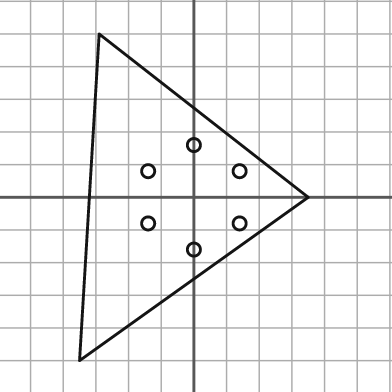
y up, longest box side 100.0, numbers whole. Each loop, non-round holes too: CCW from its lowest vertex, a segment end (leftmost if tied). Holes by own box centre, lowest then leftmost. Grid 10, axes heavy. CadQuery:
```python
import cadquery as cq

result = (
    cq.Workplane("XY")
    .moveTo(-35.0, -50.0)
    .lineTo(35.0, 0.0)
    .lineTo(-29.0, 50.0)
    .close()
    .moveTo(0.0, -16.0)
    .circle(2.0)
    .moveTo(-14.0, -8.0)
    .circle(2.0)
    .moveTo(14.0, -8.0)
    .circle(2.0)
    .moveTo(-14.0, 8.0)
    .circle(2.0)
    .moveTo(14.0, 8.0)
    .circle(2.0)
    .moveTo(0.0, 16.0)
    .circle(2.0)
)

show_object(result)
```